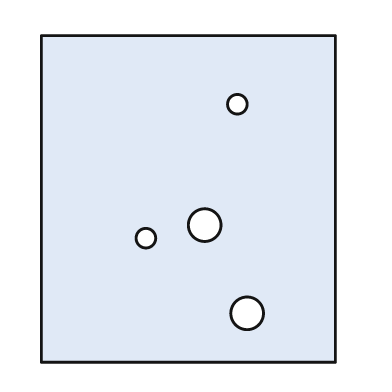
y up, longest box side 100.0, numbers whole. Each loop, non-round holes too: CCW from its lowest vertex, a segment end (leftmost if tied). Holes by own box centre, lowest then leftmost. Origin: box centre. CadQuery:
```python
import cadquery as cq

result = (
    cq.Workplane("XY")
    .moveTo(-45.0, -50.0)
    .lineTo(45.0, -50.0)
    .lineTo(45.0, 50.0)
    .lineTo(-45.0, 50.0)
    .close()
    .moveTo(18.0, -35.0)
    .circle(5.0)
    .moveTo(-13.0, -12.0)
    .circle(3.0)
    .moveTo(5.0, -8.0)
    .circle(5.0)
    .moveTo(15.0, 29.0)
    .circle(3.0)
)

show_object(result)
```